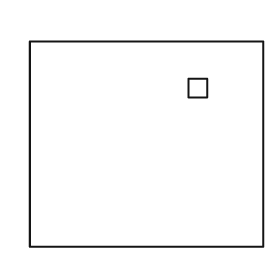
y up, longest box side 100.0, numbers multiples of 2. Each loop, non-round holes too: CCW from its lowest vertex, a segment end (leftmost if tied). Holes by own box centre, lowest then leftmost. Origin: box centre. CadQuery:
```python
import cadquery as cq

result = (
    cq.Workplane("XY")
    .moveTo(-50.0, -44.0)
    .lineTo(50.0, -44.0)
    .lineTo(50.0, 44.0)
    .lineTo(-50.0, 44.0)
    .close()
    .moveTo(18.0, 20.0)
    .lineTo(26.0, 20.0)
    .lineTo(26.0, 28.0)
    .lineTo(18.0, 28.0)
    .close()
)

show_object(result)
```